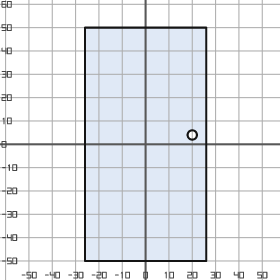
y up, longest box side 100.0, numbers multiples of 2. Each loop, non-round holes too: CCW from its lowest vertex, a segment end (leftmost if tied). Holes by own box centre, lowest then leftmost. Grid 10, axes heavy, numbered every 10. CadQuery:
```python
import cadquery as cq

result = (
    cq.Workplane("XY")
    .moveTo(-26.0, -50.0)
    .lineTo(26.0, -50.0)
    .lineTo(26.0, 50.0)
    .lineTo(-26.0, 50.0)
    .close()
    .moveTo(20.0, 4.0)
    .circle(2.0)
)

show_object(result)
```